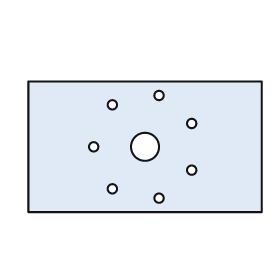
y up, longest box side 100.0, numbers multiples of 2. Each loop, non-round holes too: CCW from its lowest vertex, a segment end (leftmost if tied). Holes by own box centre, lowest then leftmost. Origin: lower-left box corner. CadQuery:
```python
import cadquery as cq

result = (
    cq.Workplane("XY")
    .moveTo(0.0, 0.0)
    .lineTo(100.0, 0.0)
    .lineTo(100.0, 56.0)
    .lineTo(0.0, 56.0)
    .close()
    .moveTo(56.0, 6.0)
    .circle(2.0)
    .moveTo(36.0, 10.0)
    .circle(2.0)
    .moveTo(70.0, 18.0)
    .circle(2.0)
    .moveTo(28.0, 28.0)
    .circle(2.0)
    .moveTo(50.0, 28.0)
    .circle(6.0)
    .moveTo(70.0, 38.0)
    .circle(2.0)
    .moveTo(36.0, 46.0)
    .circle(2.0)
    .moveTo(56.0, 50.0)
    .circle(2.0)
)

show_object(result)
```